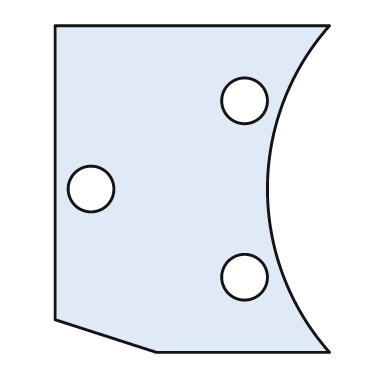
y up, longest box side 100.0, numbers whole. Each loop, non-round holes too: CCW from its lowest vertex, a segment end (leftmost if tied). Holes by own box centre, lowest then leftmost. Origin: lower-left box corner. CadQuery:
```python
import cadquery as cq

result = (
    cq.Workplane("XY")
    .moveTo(31.0, 0.0)
    .lineTo(84.0, 0.0)
    .threePointArc((65.0, 50.0), (84.0, 100.0))
    .lineTo(0.0, 100.0)
    .lineTo(0.0, 10.0)
    .close()
    .moveTo(58.0, 23.0)
    .circle(7.0)
    .moveTo(11.0, 50.0)
    .circle(7.0)
    .moveTo(58.0, 77.0)
    .circle(7.0)
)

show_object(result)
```